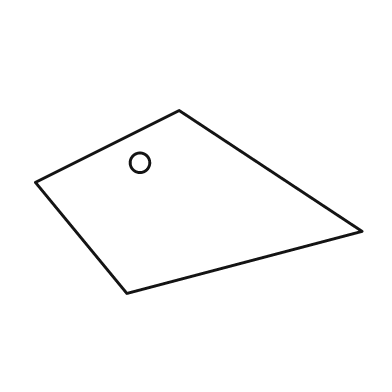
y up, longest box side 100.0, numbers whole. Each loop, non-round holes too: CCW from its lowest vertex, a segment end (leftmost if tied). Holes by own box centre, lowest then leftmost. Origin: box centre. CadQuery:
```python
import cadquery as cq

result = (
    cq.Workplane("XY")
    .moveTo(-22.0, -28.0)
    .lineTo(50.0, -9.0)
    .lineTo(-6.0, 28.0)
    .lineTo(-50.0, 6.0)
    .close()
    .moveTo(-18.0, 12.0)
    .circle(3.0)
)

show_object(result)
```